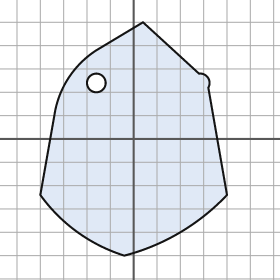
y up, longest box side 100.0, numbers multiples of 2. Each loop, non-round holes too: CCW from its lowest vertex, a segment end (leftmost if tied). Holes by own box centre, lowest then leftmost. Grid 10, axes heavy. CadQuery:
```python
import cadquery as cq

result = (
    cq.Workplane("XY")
    .moveTo(-4.0, -50.0)
    .threePointArc((20.0, -40.0), (40.0, -24.0))
    .lineTo(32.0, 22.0)
    .threePointArc((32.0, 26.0), (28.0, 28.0))
    .lineTo(4.0, 50.0)
    .lineTo(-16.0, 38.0)
    .threePointArc((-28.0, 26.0), (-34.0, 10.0))
    .lineTo(-40.0, -24.0)
    .threePointArc((-24.0, -40.0), (-4.0, -50.0))
    .close()
    .moveTo(-16.0, 24.0)
    .circle(4.0)
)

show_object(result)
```